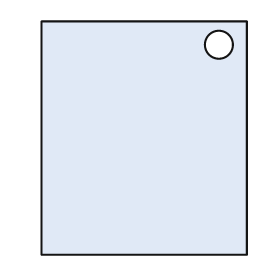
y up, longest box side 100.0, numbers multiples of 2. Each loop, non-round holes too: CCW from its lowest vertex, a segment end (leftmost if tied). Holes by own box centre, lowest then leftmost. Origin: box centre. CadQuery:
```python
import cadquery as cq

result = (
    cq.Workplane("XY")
    .moveTo(-44.0, -50.0)
    .lineTo(44.0, -50.0)
    .lineTo(44.0, 50.0)
    .lineTo(-44.0, 50.0)
    .close()
    .moveTo(32.0, 40.0)
    .circle(6.0)
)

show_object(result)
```